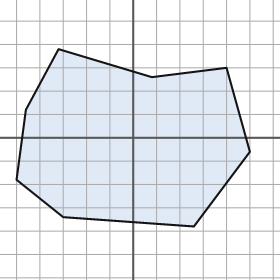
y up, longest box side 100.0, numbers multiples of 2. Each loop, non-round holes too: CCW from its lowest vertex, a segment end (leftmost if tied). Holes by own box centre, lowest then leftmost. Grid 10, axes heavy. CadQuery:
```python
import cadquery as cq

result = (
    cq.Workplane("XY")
    .moveTo(26.0, -38.0)
    .lineTo(50.0, -6.0)
    .lineTo(40.0, 30.0)
    .lineTo(8.0, 26.0)
    .lineTo(-32.0, 38.0)
    .lineTo(-46.0, 12.0)
    .lineTo(-50.0, -18.0)
    .lineTo(-30.0, -34.0)
    .close()
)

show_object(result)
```